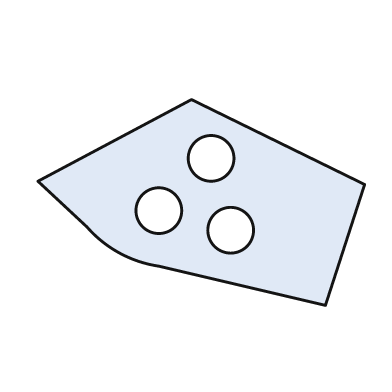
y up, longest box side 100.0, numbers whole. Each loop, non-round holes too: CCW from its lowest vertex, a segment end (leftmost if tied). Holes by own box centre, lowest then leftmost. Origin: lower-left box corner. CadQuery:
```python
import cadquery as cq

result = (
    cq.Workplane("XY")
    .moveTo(88.0, 0.0)
    .lineTo(100.0, 37.0)
    .lineTo(47.0, 63.0)
    .lineTo(0.0, 38.0)
    .lineTo(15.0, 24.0)
    .threePointArc((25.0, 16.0), (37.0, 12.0))
    .close()
    .moveTo(59.0, 23.0)
    .circle(7.0)
    .moveTo(37.0, 29.0)
    .circle(7.0)
    .moveTo(53.0, 45.0)
    .circle(7.0)
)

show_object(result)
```